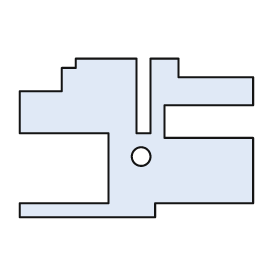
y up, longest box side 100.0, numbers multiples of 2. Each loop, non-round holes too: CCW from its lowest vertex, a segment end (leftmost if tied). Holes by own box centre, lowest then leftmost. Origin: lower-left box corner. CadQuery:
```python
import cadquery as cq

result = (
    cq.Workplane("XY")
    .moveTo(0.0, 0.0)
    .lineTo(58.0, 0.0)
    .lineTo(58.0, 6.0)
    .lineTo(100.0, 6.0)
    .lineTo(100.0, 34.0)
    .lineTo(62.0, 34.0)
    .lineTo(62.0, 48.0)
    .lineTo(100.0, 48.0)
    .lineTo(100.0, 60.0)
    .lineTo(68.0, 60.0)
    .lineTo(68.0, 68.0)
    .lineTo(56.0, 68.0)
    .lineTo(56.0, 36.0)
    .lineTo(50.0, 36.0)
    .lineTo(50.0, 68.0)
    .lineTo(24.0, 68.0)
    .lineTo(24.0, 64.0)
    .lineTo(18.0, 64.0)
    .lineTo(18.0, 54.0)
    .lineTo(0.0, 54.0)
    .lineTo(0.0, 36.0)
    .lineTo(38.0, 36.0)
    .lineTo(38.0, 6.0)
    .lineTo(0.0, 6.0)
    .close()
    .moveTo(52.0, 26.0)
    .circle(4.0)
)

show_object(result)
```